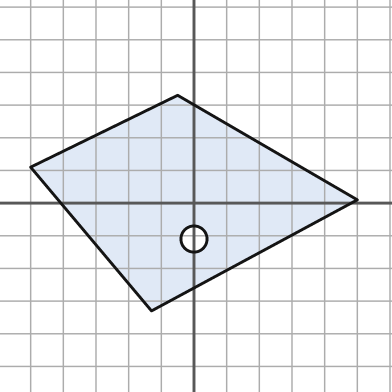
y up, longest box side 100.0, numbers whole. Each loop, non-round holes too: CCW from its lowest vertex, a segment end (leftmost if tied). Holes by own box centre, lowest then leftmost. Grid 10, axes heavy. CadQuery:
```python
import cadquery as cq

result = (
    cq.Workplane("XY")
    .moveTo(-13.0, -33.0)
    .lineTo(50.0, 1.0)
    .lineTo(-5.0, 33.0)
    .lineTo(-50.0, 11.0)
    .close()
    .moveTo(0.0, -11.0)
    .circle(4.0)
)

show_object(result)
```